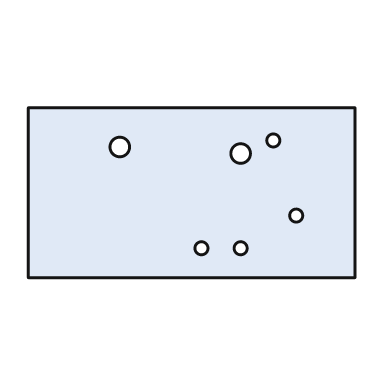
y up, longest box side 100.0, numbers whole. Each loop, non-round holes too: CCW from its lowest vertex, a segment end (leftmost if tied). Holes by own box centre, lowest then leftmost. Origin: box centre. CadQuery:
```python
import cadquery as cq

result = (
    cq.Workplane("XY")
    .moveTo(-50.0, -26.0)
    .lineTo(50.0, -26.0)
    .lineTo(50.0, 26.0)
    .lineTo(-50.0, 26.0)
    .close()
    .moveTo(3.0, -17.0)
    .circle(2.0)
    .moveTo(15.0, -17.0)
    .circle(2.0)
    .moveTo(32.0, -7.0)
    .circle(2.0)
    .moveTo(15.0, 12.0)
    .circle(3.0)
    .moveTo(-22.0, 14.0)
    .circle(3.0)
    .moveTo(25.0, 16.0)
    .circle(2.0)
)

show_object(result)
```